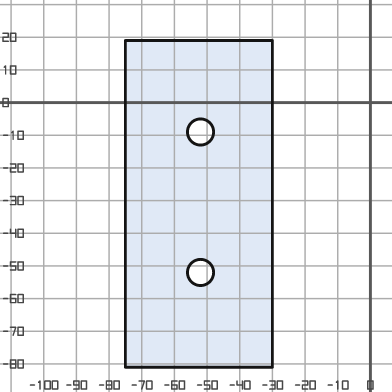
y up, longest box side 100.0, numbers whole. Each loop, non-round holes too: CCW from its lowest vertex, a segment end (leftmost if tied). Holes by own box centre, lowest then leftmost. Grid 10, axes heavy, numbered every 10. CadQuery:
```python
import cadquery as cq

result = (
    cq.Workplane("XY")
    .moveTo(-75.0, -81.0)
    .lineTo(-30.0, -81.0)
    .lineTo(-30.0, 19.0)
    .lineTo(-75.0, 19.0)
    .close()
    .moveTo(-52.0, -52.0)
    .circle(4.0)
    .moveTo(-52.0, -9.0)
    .circle(4.0)
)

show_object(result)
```